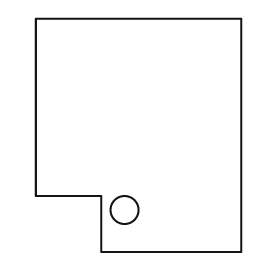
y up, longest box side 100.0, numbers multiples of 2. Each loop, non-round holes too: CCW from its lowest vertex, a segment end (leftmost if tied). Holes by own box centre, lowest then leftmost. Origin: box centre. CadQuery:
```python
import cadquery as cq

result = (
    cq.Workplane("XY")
    .moveTo(-16.0, -50.0)
    .lineTo(44.0, -50.0)
    .lineTo(44.0, 50.0)
    .lineTo(-44.0, 50.0)
    .lineTo(-44.0, -26.0)
    .lineTo(-16.0, -26.0)
    .close()
    .moveTo(-6.0, -32.0)
    .circle(6.0)
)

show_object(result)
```